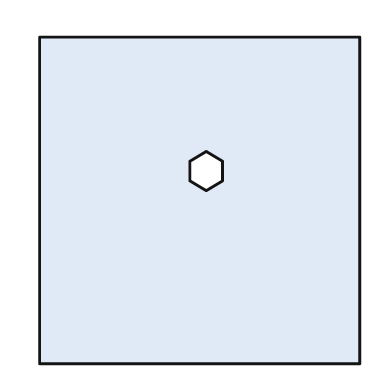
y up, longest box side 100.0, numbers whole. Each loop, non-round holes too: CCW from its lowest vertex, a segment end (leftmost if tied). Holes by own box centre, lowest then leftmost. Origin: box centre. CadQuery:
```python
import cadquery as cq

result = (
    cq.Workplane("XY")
    .moveTo(-49.0, -50.0)
    .lineTo(49.0, -50.0)
    .lineTo(49.0, 50.0)
    .lineTo(-49.0, 50.0)
    .close()
    .moveTo(2.0, 3.0)
    .lineTo(7.0, 6.0)
    .lineTo(7.0, 12.0)
    .lineTo(2.0, 15.0)
    .lineTo(-3.0, 12.0)
    .lineTo(-3.0, 6.0)
    .close()
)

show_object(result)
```